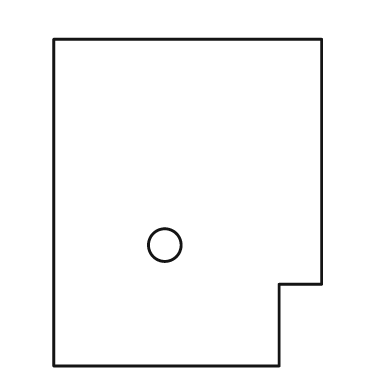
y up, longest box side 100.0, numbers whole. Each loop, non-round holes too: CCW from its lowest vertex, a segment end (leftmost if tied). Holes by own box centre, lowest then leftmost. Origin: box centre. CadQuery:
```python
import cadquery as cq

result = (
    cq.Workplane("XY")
    .moveTo(-41.0, -50.0)
    .lineTo(28.0, -50.0)
    .lineTo(28.0, -25.0)
    .lineTo(41.0, -25.0)
    .lineTo(41.0, 50.0)
    .lineTo(-41.0, 50.0)
    .close()
    .moveTo(-7.0, -13.0)
    .circle(5.0)
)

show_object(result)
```